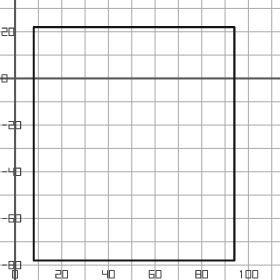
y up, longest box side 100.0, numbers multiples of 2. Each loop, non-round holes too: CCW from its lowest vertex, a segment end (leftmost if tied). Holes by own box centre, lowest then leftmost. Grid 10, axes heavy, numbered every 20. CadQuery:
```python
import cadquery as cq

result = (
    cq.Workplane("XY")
    .moveTo(8.0, -78.0)
    .lineTo(94.0, -78.0)
    .lineTo(94.0, 22.0)
    .lineTo(8.0, 22.0)
    .close()
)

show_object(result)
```